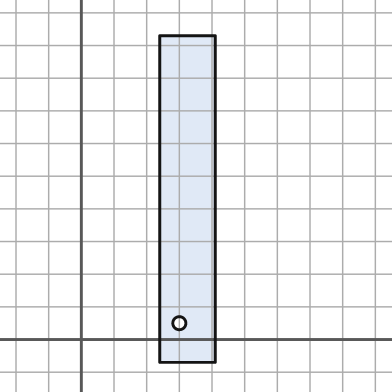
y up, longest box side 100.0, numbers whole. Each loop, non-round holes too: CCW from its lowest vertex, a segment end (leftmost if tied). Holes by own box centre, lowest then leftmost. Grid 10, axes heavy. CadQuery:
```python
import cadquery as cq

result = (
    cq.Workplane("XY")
    .moveTo(24.0, -7.0)
    .lineTo(41.0, -7.0)
    .lineTo(41.0, 93.0)
    .lineTo(24.0, 93.0)
    .close()
    .moveTo(30.0, 5.0)
    .circle(2.0)
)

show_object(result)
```